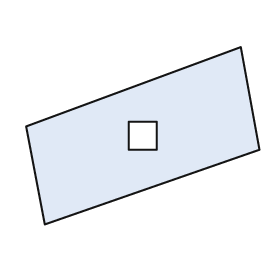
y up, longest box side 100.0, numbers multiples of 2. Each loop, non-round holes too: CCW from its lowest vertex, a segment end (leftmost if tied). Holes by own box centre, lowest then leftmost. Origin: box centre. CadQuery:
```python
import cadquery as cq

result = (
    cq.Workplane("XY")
    .moveTo(-42.0, -38.0)
    .lineTo(50.0, -6.0)
    .lineTo(42.0, 38.0)
    .lineTo(-50.0, 4.0)
    .close()
    .moveTo(-6.0, -6.0)
    .lineTo(6.0, -6.0)
    .lineTo(6.0, 6.0)
    .lineTo(-6.0, 6.0)
    .close()
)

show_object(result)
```